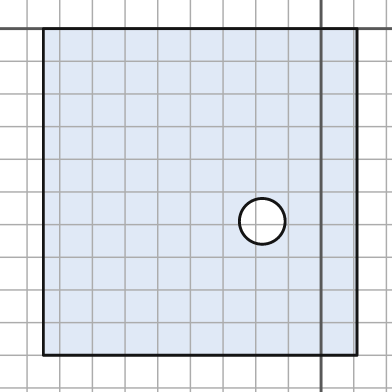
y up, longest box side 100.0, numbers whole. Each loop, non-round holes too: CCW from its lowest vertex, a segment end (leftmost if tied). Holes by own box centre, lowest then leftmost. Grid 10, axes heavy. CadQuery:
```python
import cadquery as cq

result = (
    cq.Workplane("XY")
    .moveTo(-85.0, -100.0)
    .lineTo(11.0, -100.0)
    .lineTo(11.0, 0.0)
    .lineTo(-85.0, 0.0)
    .close()
    .moveTo(-18.0, -59.0)
    .circle(7.0)
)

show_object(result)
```